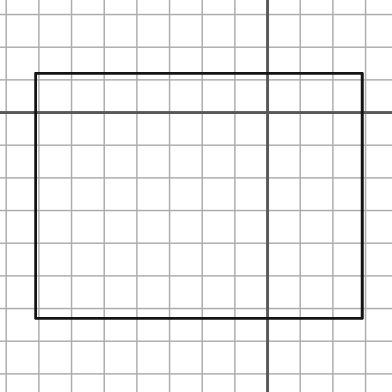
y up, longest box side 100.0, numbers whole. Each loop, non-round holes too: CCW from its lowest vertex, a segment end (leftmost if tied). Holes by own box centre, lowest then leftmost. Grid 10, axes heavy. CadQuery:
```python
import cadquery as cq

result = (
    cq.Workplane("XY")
    .moveTo(-71.0, -63.0)
    .lineTo(29.0, -63.0)
    .lineTo(29.0, 12.0)
    .lineTo(-71.0, 12.0)
    .close()
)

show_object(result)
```